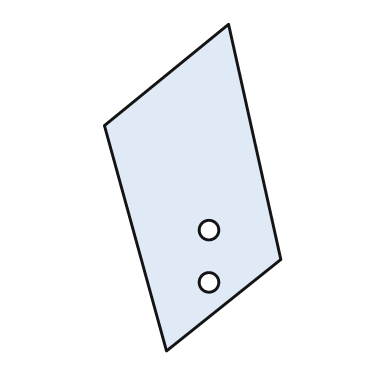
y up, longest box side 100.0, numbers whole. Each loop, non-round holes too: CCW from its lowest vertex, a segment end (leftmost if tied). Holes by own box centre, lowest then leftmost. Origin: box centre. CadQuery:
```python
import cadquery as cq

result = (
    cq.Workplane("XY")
    .moveTo(-8.0, -50.0)
    .lineTo(27.0, -22.0)
    .lineTo(11.0, 50.0)
    .lineTo(-27.0, 19.0)
    .close()
    .moveTo(5.0, -29.0)
    .circle(3.0)
    .moveTo(5.0, -13.0)
    .circle(3.0)
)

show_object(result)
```